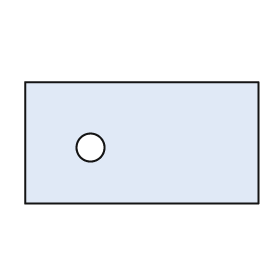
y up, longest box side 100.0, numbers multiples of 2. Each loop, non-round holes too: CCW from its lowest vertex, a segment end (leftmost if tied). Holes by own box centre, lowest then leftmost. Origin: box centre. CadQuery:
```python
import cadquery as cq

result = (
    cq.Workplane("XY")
    .moveTo(-50.0, -26.0)
    .lineTo(50.0, -26.0)
    .lineTo(50.0, 26.0)
    .lineTo(-50.0, 26.0)
    .close()
    .moveTo(-22.0, -2.0)
    .circle(6.0)
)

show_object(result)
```